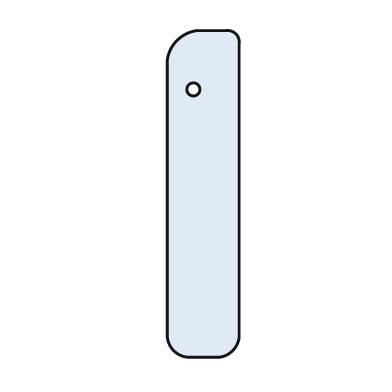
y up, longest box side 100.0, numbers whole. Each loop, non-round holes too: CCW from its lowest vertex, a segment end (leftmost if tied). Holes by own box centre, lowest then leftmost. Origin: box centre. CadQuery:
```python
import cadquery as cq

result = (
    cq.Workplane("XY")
    .moveTo(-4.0, -50.0)
    .lineTo(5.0, -50.0)
    .threePointArc((9.0, -48.0), (11.0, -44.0))
    .lineTo(11.0, 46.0)
    .threePointArc((10.0, 49.0), (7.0, 50.0))
    .lineTo(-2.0, 50.0)
    .threePointArc((-8.0, 47.0), (-11.0, 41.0))
    .lineTo(-11.0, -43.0)
    .threePointArc((-9.0, -48.0), (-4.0, -50.0))
    .close()
    .moveTo(-3.0, 32.0)
    .circle(2.0)
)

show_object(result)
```